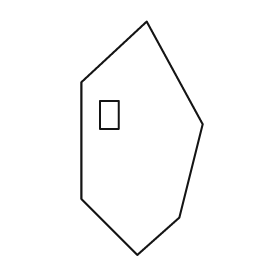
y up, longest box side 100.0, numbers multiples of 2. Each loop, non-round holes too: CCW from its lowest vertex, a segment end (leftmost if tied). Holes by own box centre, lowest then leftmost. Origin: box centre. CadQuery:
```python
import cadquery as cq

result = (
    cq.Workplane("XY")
    .moveTo(-2.0, -50.0)
    .lineTo(16.0, -34.0)
    .lineTo(26.0, 6.0)
    .lineTo(2.0, 50.0)
    .lineTo(-26.0, 24.0)
    .lineTo(-26.0, -26.0)
    .close()
    .moveTo(-18.0, 4.0)
    .lineTo(-10.0, 4.0)
    .lineTo(-10.0, 16.0)
    .lineTo(-18.0, 16.0)
    .close()
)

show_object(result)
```